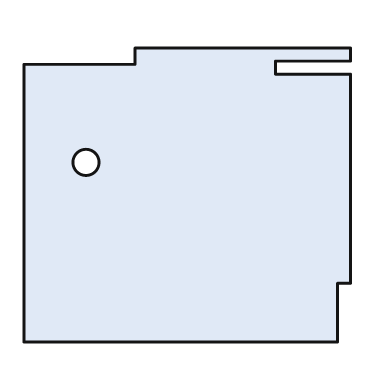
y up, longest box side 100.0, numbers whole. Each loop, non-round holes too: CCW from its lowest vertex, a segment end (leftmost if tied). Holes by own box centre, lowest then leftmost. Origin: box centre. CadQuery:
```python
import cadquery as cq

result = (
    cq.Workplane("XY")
    .moveTo(-50.0, -45.0)
    .lineTo(46.0, -45.0)
    .lineTo(46.0, -27.0)
    .lineTo(50.0, -27.0)
    .lineTo(50.0, 37.0)
    .lineTo(27.0, 37.0)
    .lineTo(27.0, 41.0)
    .lineTo(50.0, 41.0)
    .lineTo(50.0, 45.0)
    .lineTo(-16.0, 45.0)
    .lineTo(-16.0, 40.0)
    .lineTo(-50.0, 40.0)
    .close()
    .moveTo(-31.0, 10.0)
    .circle(4.0)
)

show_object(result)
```